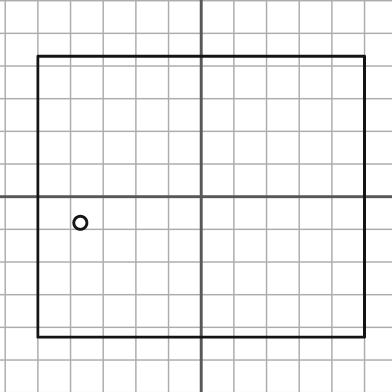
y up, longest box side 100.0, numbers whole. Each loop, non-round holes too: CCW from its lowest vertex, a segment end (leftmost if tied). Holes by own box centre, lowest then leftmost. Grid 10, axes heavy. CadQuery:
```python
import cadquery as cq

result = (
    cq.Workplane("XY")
    .moveTo(-50.0, -43.0)
    .lineTo(50.0, -43.0)
    .lineTo(50.0, 43.0)
    .lineTo(-50.0, 43.0)
    .close()
    .moveTo(-37.0, -8.0)
    .circle(2.0)
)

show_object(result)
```